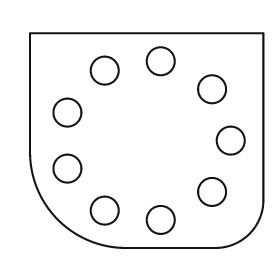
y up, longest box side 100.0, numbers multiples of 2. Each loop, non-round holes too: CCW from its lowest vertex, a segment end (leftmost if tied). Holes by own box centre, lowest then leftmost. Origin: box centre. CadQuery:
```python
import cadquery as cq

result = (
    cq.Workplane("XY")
    .moveTo(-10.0, -46.0)
    .lineTo(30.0, -46.0)
    .threePointArc((44.0, -40.0), (50.0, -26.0))
    .lineTo(50.0, 46.0)
    .lineTo(-50.0, 46.0)
    .lineTo(-50.0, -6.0)
    .threePointArc((-38.0, -34.0), (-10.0, -46.0))
    .close()
    .moveTo(6.0, -34.0)
    .circle(6.0)
    .moveTo(-18.0, -30.0)
    .circle(6.0)
    .moveTo(28.0, -22.0)
    .circle(6.0)
    .moveTo(-34.0, -12.0)
    .circle(6.0)
    .moveTo(36.0, 0.0)
    .circle(6.0)
    .moveTo(-34.0, 12.0)
    .circle(6.0)
    .moveTo(28.0, 22.0)
    .circle(6.0)
    .moveTo(-18.0, 30.0)
    .circle(6.0)
    .moveTo(6.0, 34.0)
    .circle(6.0)
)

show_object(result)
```